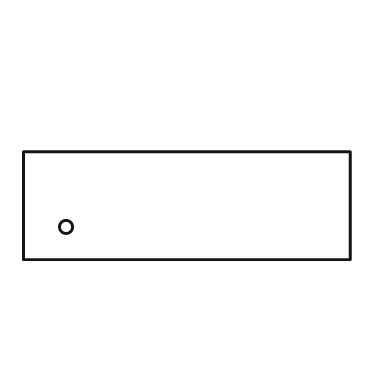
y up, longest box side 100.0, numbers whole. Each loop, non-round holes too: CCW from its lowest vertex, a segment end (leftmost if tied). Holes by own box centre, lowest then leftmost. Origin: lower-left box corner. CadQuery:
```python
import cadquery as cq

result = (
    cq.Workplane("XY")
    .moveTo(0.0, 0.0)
    .lineTo(100.0, 0.0)
    .lineTo(100.0, 33.0)
    .lineTo(0.0, 33.0)
    .close()
    .moveTo(13.0, 10.0)
    .circle(2.0)
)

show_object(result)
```